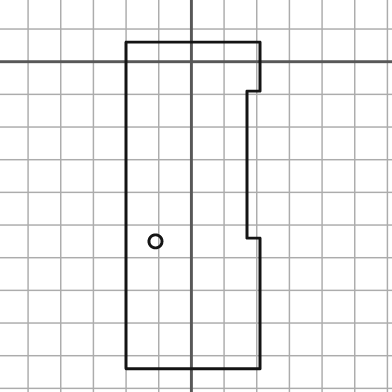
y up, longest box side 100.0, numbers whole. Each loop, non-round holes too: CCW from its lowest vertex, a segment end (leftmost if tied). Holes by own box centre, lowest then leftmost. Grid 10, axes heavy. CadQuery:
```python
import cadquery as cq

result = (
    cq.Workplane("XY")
    .moveTo(-20.0, -94.0)
    .lineTo(21.0, -94.0)
    .lineTo(21.0, -54.0)
    .lineTo(17.0, -54.0)
    .lineTo(17.0, -9.0)
    .lineTo(21.0, -9.0)
    .lineTo(21.0, 6.0)
    .lineTo(-20.0, 6.0)
    .close()
    .moveTo(-11.0, -55.0)
    .circle(2.0)
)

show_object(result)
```